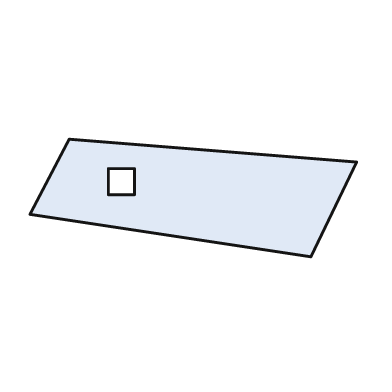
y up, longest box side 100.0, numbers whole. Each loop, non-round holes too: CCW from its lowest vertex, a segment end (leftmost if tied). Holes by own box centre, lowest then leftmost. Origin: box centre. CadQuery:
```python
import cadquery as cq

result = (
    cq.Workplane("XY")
    .moveTo(36.0, -18.0)
    .lineTo(50.0, 11.0)
    .lineTo(-38.0, 18.0)
    .lineTo(-50.0, -5.0)
    .close()
    .moveTo(-26.0, 1.0)
    .lineTo(-18.0, 1.0)
    .lineTo(-18.0, 9.0)
    .lineTo(-26.0, 9.0)
    .close()
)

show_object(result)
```